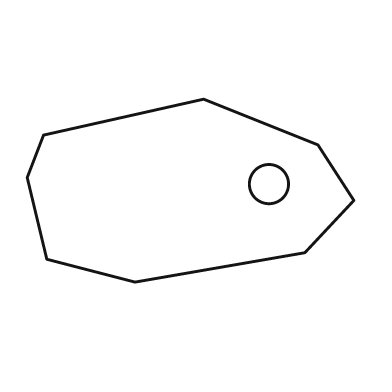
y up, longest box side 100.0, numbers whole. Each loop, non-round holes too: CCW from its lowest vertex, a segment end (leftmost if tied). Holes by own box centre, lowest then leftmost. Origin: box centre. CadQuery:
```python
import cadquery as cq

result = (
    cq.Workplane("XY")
    .moveTo(-17.0, -28.0)
    .lineTo(35.0, -19.0)
    .lineTo(50.0, -3.0)
    .lineTo(39.0, 14.0)
    .lineTo(4.0, 28.0)
    .lineTo(-45.0, 17.0)
    .lineTo(-50.0, 4.0)
    .lineTo(-44.0, -21.0)
    .close()
    .moveTo(24.0, 2.0)
    .circle(6.0)
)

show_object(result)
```